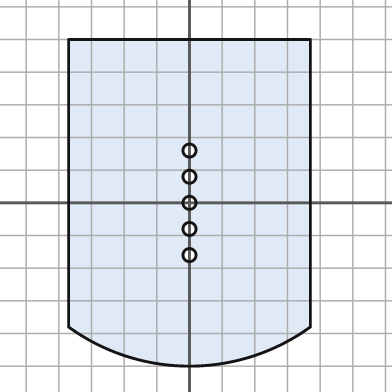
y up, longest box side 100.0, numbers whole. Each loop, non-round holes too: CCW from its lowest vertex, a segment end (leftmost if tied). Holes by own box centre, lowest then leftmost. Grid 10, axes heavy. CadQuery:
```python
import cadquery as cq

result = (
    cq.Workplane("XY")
    .moveTo(-37.0, -38.0)
    .threePointArc((0.0, -50.0), (37.0, -38.0))
    .lineTo(37.0, 50.0)
    .lineTo(-37.0, 50.0)
    .close()
    .moveTo(0.0, -16.0)
    .circle(2.0)
    .moveTo(0.0, -8.0)
    .circle(2.0)
    .moveTo(0.0, 0.0)
    .circle(2.0)
    .moveTo(0.0, 8.0)
    .circle(2.0)
    .moveTo(0.0, 16.0)
    .circle(2.0)
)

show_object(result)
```